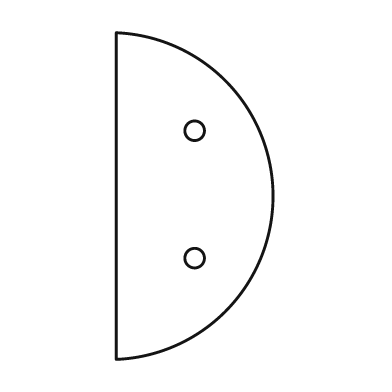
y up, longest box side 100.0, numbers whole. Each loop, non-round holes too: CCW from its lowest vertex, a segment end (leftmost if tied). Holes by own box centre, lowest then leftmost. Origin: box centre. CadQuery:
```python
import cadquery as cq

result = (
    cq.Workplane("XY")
    .moveTo(-24.0, -50.0)
    .threePointArc((24.0, 0.0), (-24.0, 50.0))
    .close()
    .moveTo(0.0, -19.0)
    .circle(3.0)
    .moveTo(0.0, 20.0)
    .circle(3.0)
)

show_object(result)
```